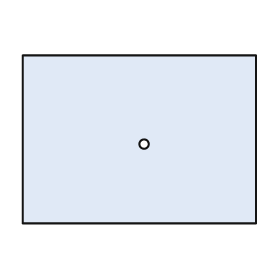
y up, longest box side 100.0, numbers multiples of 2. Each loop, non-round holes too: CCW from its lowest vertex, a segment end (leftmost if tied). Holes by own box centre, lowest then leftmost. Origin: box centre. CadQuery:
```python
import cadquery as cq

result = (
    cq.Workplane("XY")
    .moveTo(-50.0, -36.0)
    .lineTo(50.0, -36.0)
    .lineTo(50.0, 36.0)
    .lineTo(-50.0, 36.0)
    .close()
    .moveTo(2.0, -2.0)
    .circle(2.0)
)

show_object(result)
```